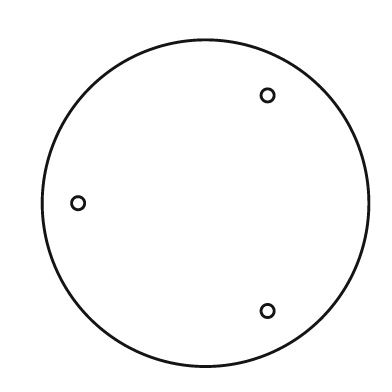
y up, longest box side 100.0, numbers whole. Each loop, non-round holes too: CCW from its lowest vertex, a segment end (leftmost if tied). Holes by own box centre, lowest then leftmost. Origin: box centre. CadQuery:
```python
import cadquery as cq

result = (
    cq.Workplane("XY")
    .moveTo(0.0, 0.0)
    .circle(50.0)
    .moveTo(19.0, -33.0)
    .circle(2.0)
    .moveTo(-39.0, 0.0)
    .circle(2.0)
    .moveTo(19.0, 33.0)
    .circle(2.0)
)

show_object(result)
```